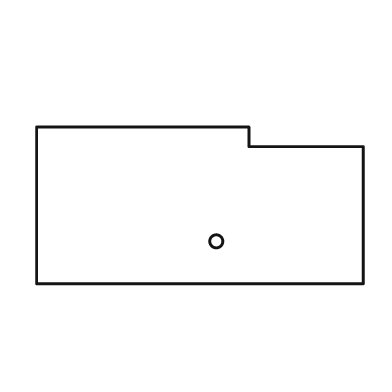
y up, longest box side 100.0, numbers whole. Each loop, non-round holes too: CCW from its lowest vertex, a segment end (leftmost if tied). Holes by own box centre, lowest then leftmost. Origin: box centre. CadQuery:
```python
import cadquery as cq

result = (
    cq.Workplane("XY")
    .moveTo(-50.0, -24.0)
    .lineTo(50.0, -24.0)
    .lineTo(50.0, 18.0)
    .lineTo(15.0, 18.0)
    .lineTo(15.0, 24.0)
    .lineTo(-50.0, 24.0)
    .close()
    .moveTo(5.0, -11.0)
    .circle(2.0)
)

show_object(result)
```